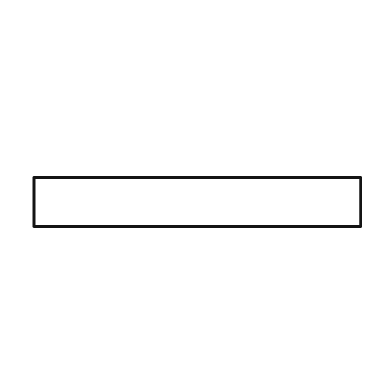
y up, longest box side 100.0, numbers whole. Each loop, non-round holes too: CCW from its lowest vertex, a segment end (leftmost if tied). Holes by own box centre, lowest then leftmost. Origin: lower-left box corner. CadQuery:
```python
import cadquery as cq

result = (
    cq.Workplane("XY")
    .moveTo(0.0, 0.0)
    .lineTo(100.0, 0.0)
    .lineTo(100.0, 15.0)
    .lineTo(0.0, 15.0)
    .close()
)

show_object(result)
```